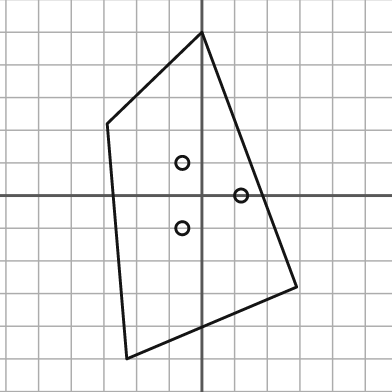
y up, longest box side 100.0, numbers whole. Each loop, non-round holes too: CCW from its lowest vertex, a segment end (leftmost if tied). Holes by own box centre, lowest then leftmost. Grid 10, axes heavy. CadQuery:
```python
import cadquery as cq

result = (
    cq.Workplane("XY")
    .moveTo(-23.0, -50.0)
    .lineTo(29.0, -28.0)
    .lineTo(0.0, 50.0)
    .lineTo(-29.0, 22.0)
    .close()
    .moveTo(-6.0, -10.0)
    .circle(2.0)
    .moveTo(12.0, 0.0)
    .circle(2.0)
    .moveTo(-6.0, 10.0)
    .circle(2.0)
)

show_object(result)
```